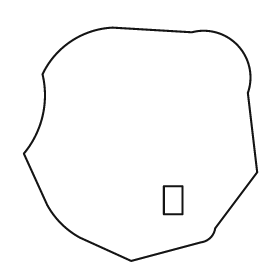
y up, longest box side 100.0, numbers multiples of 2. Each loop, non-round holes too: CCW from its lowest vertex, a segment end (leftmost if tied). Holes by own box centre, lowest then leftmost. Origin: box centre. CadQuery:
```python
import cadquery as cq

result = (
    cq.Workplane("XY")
    .moveTo(-4.0, -50.0)
    .lineTo(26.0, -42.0)
    .threePointArc((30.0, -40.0), (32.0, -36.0))
    .lineTo(50.0, -12.0)
    .lineTo(46.0, 22.0)
    .threePointArc((42.0, 42.0), (22.0, 48.0))
    .lineTo(-12.0, 50.0)
    .threePointArc((-30.0, 44.0), (-42.0, 30.0))
    .threePointArc((-42.0, 12.0), (-50.0, -4.0))
    .lineTo(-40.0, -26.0)
    .threePointArc((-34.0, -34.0), (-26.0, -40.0))
    .close()
    .moveTo(10.0, -30.0)
    .lineTo(18.0, -30.0)
    .lineTo(18.0, -18.0)
    .lineTo(10.0, -18.0)
    .close()
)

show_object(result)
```